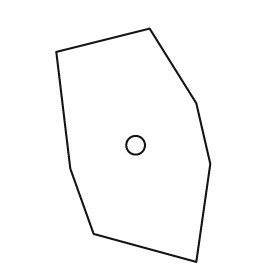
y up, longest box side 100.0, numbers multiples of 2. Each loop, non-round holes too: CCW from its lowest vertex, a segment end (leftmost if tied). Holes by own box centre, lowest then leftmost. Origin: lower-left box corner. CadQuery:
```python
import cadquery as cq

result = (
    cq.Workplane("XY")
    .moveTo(60.0, 0.0)
    .lineTo(66.0, 42.0)
    .lineTo(60.0, 68.0)
    .lineTo(40.0, 100.0)
    .lineTo(0.0, 90.0)
    .lineTo(6.0, 40.0)
    .lineTo(16.0, 12.0)
    .close()
    .moveTo(34.0, 50.0)
    .circle(4.0)
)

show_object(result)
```